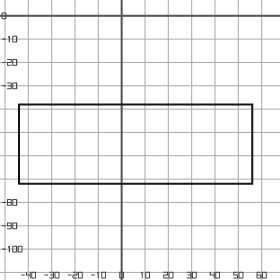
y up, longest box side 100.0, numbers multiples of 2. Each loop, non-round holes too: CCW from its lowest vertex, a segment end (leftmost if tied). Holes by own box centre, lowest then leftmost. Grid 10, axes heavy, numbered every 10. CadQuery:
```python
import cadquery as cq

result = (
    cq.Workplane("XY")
    .moveTo(-44.0, -72.0)
    .lineTo(56.0, -72.0)
    .lineTo(56.0, -38.0)
    .lineTo(-44.0, -38.0)
    .close()
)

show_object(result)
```